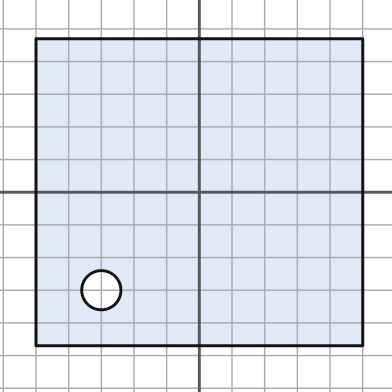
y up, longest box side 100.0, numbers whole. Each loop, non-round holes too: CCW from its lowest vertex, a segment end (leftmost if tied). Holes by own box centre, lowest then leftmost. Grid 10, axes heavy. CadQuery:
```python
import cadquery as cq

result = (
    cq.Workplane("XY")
    .moveTo(-50.0, -47.0)
    .lineTo(50.0, -47.0)
    .lineTo(50.0, 47.0)
    .lineTo(-50.0, 47.0)
    .close()
    .moveTo(-30.0, -30.0)
    .circle(6.0)
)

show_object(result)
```